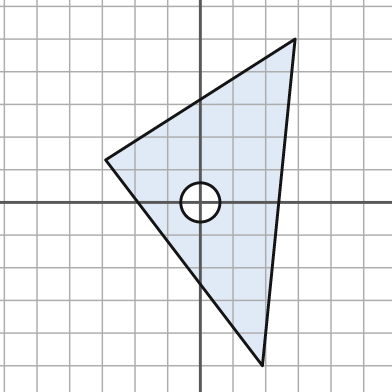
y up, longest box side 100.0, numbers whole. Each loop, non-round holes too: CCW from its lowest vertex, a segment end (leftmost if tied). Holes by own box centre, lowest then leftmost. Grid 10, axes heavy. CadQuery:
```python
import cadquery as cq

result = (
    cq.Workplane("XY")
    .moveTo(19.0, -50.0)
    .lineTo(29.0, 50.0)
    .lineTo(-29.0, 13.0)
    .close()
    .moveTo(0.0, 0.0)
    .circle(6.0)
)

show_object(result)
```